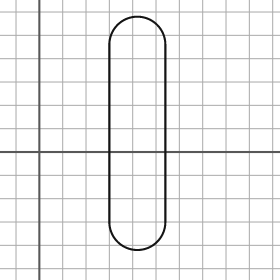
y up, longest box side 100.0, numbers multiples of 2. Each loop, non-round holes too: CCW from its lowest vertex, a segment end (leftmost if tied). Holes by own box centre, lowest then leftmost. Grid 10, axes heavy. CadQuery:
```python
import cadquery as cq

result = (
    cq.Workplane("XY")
    .moveTo(30.0, -30.0)
    .threePointArc((42.0, -42.0), (54.0, -30.0))
    .lineTo(54.0, 46.0)
    .threePointArc((42.0, 58.0), (30.0, 46.0))
    .close()
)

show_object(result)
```